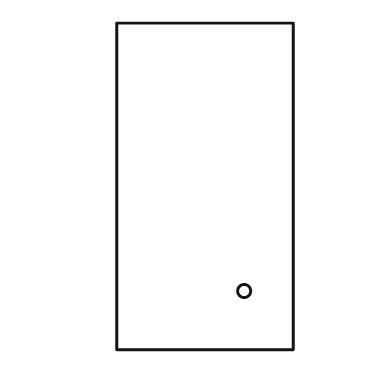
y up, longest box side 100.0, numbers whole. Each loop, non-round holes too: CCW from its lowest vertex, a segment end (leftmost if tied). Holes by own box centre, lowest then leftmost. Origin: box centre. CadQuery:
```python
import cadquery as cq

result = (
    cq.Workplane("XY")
    .moveTo(-27.0, -50.0)
    .lineTo(27.0, -50.0)
    .lineTo(27.0, 50.0)
    .lineTo(-27.0, 50.0)
    .close()
    .moveTo(12.0, -32.0)
    .circle(2.0)
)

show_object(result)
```